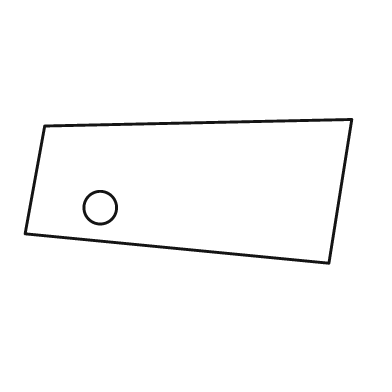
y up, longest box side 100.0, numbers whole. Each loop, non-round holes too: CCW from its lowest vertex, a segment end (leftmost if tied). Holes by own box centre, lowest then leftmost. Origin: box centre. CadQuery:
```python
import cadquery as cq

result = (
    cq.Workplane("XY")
    .moveTo(43.0, -22.0)
    .lineTo(50.0, 22.0)
    .lineTo(-44.0, 20.0)
    .lineTo(-50.0, -13.0)
    .close()
    .moveTo(-27.0, -5.0)
    .circle(5.0)
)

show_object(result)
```